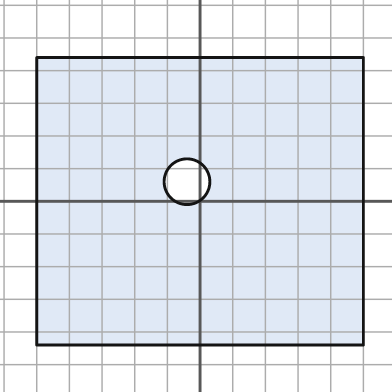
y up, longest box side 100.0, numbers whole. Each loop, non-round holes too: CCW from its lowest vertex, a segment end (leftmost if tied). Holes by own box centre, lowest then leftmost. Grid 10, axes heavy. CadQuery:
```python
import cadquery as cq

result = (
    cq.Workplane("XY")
    .moveTo(-50.0, -44.0)
    .lineTo(50.0, -44.0)
    .lineTo(50.0, 44.0)
    .lineTo(-50.0, 44.0)
    .close()
    .moveTo(-4.0, 6.0)
    .circle(7.0)
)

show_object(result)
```